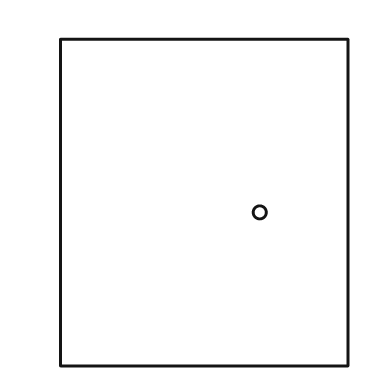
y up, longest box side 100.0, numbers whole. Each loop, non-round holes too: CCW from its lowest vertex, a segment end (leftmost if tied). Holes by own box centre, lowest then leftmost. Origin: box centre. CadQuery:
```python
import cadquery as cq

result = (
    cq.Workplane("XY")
    .moveTo(-44.0, -50.0)
    .lineTo(44.0, -50.0)
    .lineTo(44.0, 50.0)
    .lineTo(-44.0, 50.0)
    .close()
    .moveTo(17.0, -3.0)
    .circle(2.0)
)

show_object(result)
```